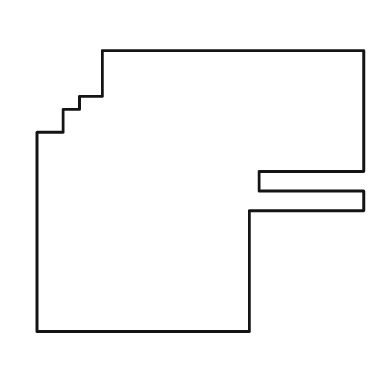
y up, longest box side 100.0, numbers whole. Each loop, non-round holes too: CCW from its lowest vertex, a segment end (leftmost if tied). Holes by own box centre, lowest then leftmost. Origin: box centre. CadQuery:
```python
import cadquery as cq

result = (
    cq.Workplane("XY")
    .moveTo(-50.0, -43.0)
    .lineTo(15.0, -43.0)
    .lineTo(15.0, -6.0)
    .lineTo(50.0, -6.0)
    .lineTo(50.0, 0.0)
    .lineTo(18.0, 0.0)
    .lineTo(18.0, 6.0)
    .lineTo(50.0, 6.0)
    .lineTo(50.0, 43.0)
    .lineTo(-30.0, 43.0)
    .lineTo(-30.0, 29.0)
    .lineTo(-37.0, 29.0)
    .lineTo(-37.0, 25.0)
    .lineTo(-42.0, 25.0)
    .lineTo(-42.0, 18.0)
    .lineTo(-50.0, 18.0)
    .close()
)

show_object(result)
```